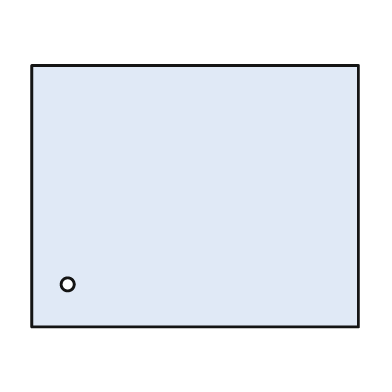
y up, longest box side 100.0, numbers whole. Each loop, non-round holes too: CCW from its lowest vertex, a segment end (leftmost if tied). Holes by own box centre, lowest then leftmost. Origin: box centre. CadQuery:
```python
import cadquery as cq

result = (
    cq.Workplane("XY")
    .moveTo(-50.0, -40.0)
    .lineTo(50.0, -40.0)
    .lineTo(50.0, 40.0)
    .lineTo(-50.0, 40.0)
    .close()
    .moveTo(-39.0, -27.0)
    .circle(2.0)
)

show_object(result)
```